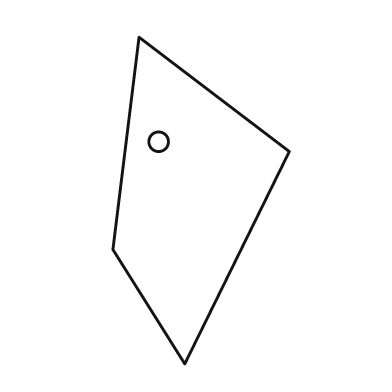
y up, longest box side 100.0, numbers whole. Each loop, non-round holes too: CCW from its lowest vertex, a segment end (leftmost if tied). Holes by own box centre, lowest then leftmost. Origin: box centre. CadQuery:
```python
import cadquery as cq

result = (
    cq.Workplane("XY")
    .moveTo(-5.0, -50.0)
    .lineTo(27.0, 15.0)
    .lineTo(-19.0, 50.0)
    .lineTo(-27.0, -15.0)
    .close()
    .moveTo(-13.0, 18.0)
    .circle(3.0)
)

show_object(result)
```